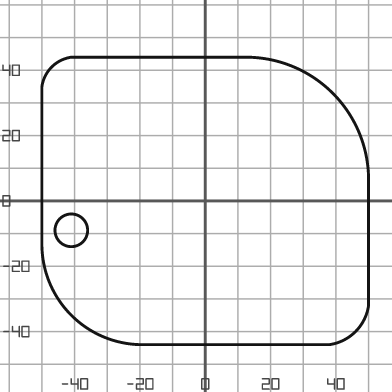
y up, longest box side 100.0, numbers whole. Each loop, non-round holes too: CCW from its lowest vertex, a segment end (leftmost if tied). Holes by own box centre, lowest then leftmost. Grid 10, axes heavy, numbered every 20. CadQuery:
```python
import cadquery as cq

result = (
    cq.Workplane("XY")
    .moveTo(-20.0, -44.0)
    .lineTo(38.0, -44.0)
    .threePointArc((46.0, -40.0), (50.0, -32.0))
    .lineTo(50.0, 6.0)
    .threePointArc((39.0, 33.0), (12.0, 44.0))
    .lineTo(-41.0, 44.0)
    .threePointArc((-47.0, 41.0), (-50.0, 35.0))
    .lineTo(-50.0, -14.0)
    .threePointArc((-41.0, -35.0), (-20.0, -44.0))
    .close()
    .moveTo(-41.0, -9.0)
    .circle(5.0)
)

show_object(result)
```